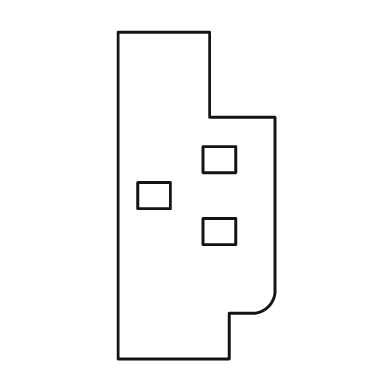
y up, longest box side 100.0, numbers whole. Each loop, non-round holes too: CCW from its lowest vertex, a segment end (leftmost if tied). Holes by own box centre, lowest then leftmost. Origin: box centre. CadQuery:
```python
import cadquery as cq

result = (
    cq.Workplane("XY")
    .moveTo(-24.0, -50.0)
    .lineTo(10.0, -50.0)
    .lineTo(10.0, -36.0)
    .lineTo(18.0, -36.0)
    .threePointArc((22.0, -34.0), (24.0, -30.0))
    .lineTo(24.0, 24.0)
    .lineTo(4.0, 24.0)
    .lineTo(4.0, 50.0)
    .lineTo(-24.0, 50.0)
    .close()
    .moveTo(2.0, -15.0)
    .lineTo(12.0, -15.0)
    .lineTo(12.0, -7.0)
    .lineTo(2.0, -7.0)
    .close()
    .moveTo(-18.0, -4.0)
    .lineTo(-8.0, -4.0)
    .lineTo(-8.0, 4.0)
    .lineTo(-18.0, 4.0)
    .close()
    .moveTo(2.0, 7.0)
    .lineTo(12.0, 7.0)
    .lineTo(12.0, 15.0)
    .lineTo(2.0, 15.0)
    .close()
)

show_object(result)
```